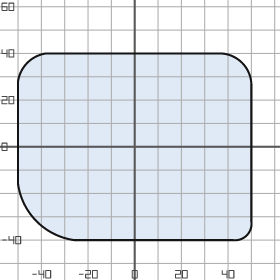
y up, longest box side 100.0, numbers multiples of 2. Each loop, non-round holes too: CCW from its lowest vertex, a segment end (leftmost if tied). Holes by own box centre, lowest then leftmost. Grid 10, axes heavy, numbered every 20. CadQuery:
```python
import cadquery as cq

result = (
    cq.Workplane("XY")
    .moveTo(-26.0, -40.0)
    .lineTo(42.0, -40.0)
    .threePointArc((48.0, -38.0), (50.0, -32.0))
    .lineTo(50.0, 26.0)
    .threePointArc((46.0, 36.0), (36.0, 40.0))
    .lineTo(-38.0, 40.0)
    .threePointArc((-46.0, 36.0), (-50.0, 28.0))
    .lineTo(-50.0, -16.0)
    .threePointArc((-42.0, -32.0), (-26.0, -40.0))
    .close()
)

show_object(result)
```